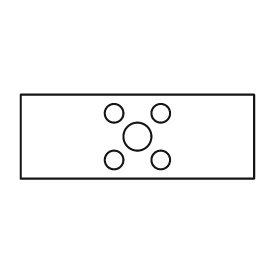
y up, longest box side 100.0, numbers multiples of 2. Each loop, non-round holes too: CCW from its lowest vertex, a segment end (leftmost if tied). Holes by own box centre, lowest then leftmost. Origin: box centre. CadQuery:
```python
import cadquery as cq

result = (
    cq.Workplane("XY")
    .moveTo(-50.0, -18.0)
    .lineTo(50.0, -18.0)
    .lineTo(50.0, 18.0)
    .lineTo(-50.0, 18.0)
    .close()
    .moveTo(-10.0, -10.0)
    .circle(4.0)
    .moveTo(10.0, -10.0)
    .circle(4.0)
    .moveTo(0.0, 0.0)
    .circle(6.0)
    .moveTo(-10.0, 10.0)
    .circle(4.0)
    .moveTo(10.0, 10.0)
    .circle(4.0)
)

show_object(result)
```